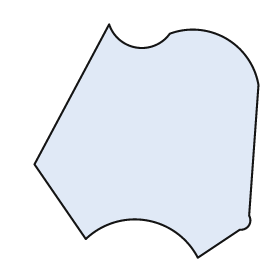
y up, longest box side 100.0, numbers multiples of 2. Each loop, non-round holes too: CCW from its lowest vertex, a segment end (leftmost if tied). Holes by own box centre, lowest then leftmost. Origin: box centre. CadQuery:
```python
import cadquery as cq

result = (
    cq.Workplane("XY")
    .moveTo(22.0, -50.0)
    .lineTo(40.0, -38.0)
    .threePointArc((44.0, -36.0), (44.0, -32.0))
    .lineTo(48.0, 24.0)
    .threePointArc((34.0, 44.0), (10.0, 46.0))
    .threePointArc((-4.0, 40.0), (-16.0, 50.0))
    .lineTo(-48.0, -10.0)
    .lineTo(-26.0, -42.0)
    .threePointArc((0.0, -34.0), (22.0, -50.0))
    .close()
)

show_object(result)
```